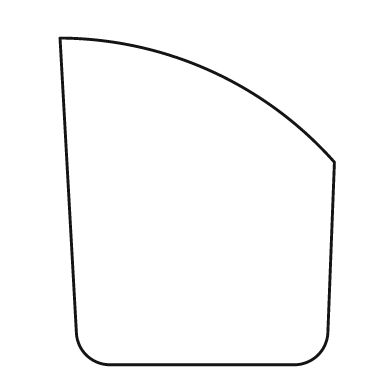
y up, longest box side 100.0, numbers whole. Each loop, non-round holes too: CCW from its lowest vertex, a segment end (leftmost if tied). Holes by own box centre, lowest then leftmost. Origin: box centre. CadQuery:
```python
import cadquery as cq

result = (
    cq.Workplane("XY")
    .moveTo(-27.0, -50.0)
    .lineTo(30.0, -50.0)
    .threePointArc((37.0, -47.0), (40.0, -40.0))
    .lineTo(42.0, 12.0)
    .threePointArc((4.0, 40.0), (-42.0, 50.0))
    .lineTo(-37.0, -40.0)
    .threePointArc((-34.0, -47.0), (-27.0, -50.0))
    .close()
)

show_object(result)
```